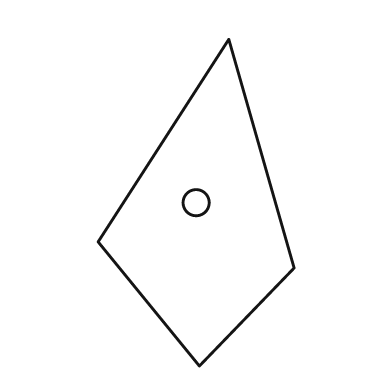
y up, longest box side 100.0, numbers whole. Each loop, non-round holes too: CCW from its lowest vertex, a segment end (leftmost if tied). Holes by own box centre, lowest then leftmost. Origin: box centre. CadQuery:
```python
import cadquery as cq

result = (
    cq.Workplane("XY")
    .moveTo(1.0, -50.0)
    .lineTo(30.0, -20.0)
    .lineTo(10.0, 50.0)
    .lineTo(-30.0, -12.0)
    .close()
    .moveTo(0.0, 0.0)
    .circle(4.0)
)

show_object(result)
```